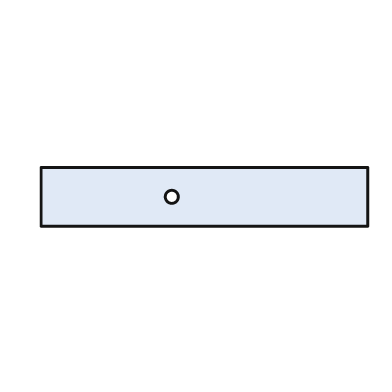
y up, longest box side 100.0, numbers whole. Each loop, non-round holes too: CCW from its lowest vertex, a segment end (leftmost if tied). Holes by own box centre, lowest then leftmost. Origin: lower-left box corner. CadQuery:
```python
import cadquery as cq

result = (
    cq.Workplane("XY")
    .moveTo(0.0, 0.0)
    .lineTo(100.0, 0.0)
    .lineTo(100.0, 18.0)
    .lineTo(0.0, 18.0)
    .close()
    .moveTo(40.0, 9.0)
    .circle(2.0)
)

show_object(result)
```